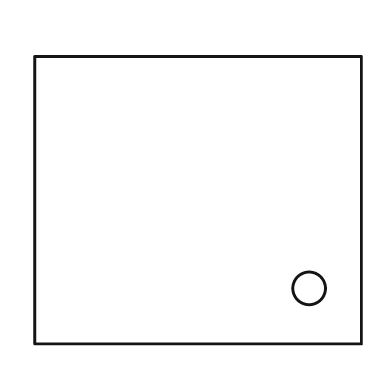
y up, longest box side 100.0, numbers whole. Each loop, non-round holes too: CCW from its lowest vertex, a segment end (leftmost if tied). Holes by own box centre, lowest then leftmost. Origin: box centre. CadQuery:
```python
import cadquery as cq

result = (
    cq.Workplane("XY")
    .moveTo(-50.0, -44.0)
    .lineTo(50.0, -44.0)
    .lineTo(50.0, 44.0)
    .lineTo(-50.0, 44.0)
    .close()
    .moveTo(34.0, -27.0)
    .circle(5.0)
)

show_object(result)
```